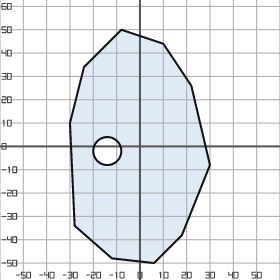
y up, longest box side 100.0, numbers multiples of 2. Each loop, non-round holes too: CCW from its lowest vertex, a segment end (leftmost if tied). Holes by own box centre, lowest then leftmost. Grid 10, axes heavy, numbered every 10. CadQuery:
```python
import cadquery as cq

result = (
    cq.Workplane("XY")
    .moveTo(6.0, -50.0)
    .lineTo(18.0, -38.0)
    .lineTo(30.0, -8.0)
    .lineTo(22.0, 26.0)
    .lineTo(10.0, 44.0)
    .lineTo(-8.0, 50.0)
    .lineTo(-24.0, 34.0)
    .lineTo(-30.0, 10.0)
    .lineTo(-28.0, -34.0)
    .lineTo(-12.0, -48.0)
    .close()
    .moveTo(-14.0, -2.0)
    .circle(6.0)
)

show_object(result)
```